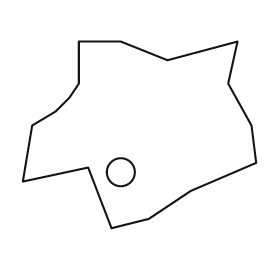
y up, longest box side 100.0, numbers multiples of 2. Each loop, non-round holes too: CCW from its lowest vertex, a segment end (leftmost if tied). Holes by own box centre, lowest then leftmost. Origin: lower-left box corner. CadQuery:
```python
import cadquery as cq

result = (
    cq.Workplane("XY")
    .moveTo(38.0, 0.0)
    .lineTo(54.0, 4.0)
    .lineTo(72.0, 16.0)
    .lineTo(100.0, 28.0)
    .lineTo(98.0, 44.0)
    .lineTo(88.0, 62.0)
    .lineTo(92.0, 80.0)
    .lineTo(62.0, 72.0)
    .lineTo(42.0, 80.0)
    .lineTo(24.0, 80.0)
    .lineTo(24.0, 62.0)
    .lineTo(20.0, 56.0)
    .lineTo(14.0, 50.0)
    .lineTo(4.0, 44.0)
    .lineTo(0.0, 20.0)
    .lineTo(28.0, 26.0)
    .close()
    .moveTo(42.0, 24.0)
    .circle(6.0)
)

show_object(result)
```